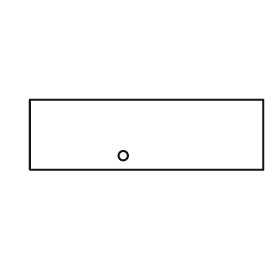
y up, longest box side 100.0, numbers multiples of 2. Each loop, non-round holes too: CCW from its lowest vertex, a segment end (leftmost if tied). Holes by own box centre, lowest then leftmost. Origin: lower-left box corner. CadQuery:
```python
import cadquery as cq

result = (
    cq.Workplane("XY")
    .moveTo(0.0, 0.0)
    .lineTo(100.0, 0.0)
    .lineTo(100.0, 30.0)
    .lineTo(0.0, 30.0)
    .close()
    .moveTo(40.0, 6.0)
    .circle(2.0)
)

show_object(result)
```